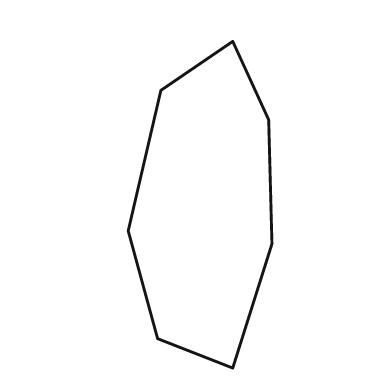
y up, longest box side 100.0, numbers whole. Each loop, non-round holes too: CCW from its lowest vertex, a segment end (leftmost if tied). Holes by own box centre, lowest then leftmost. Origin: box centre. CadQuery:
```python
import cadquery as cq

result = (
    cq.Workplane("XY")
    .moveTo(10.0, -50.0)
    .lineTo(22.0, -12.0)
    .lineTo(21.0, 26.0)
    .lineTo(10.0, 50.0)
    .lineTo(-12.0, 35.0)
    .lineTo(-22.0, -8.0)
    .lineTo(-13.0, -41.0)
    .close()
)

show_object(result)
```